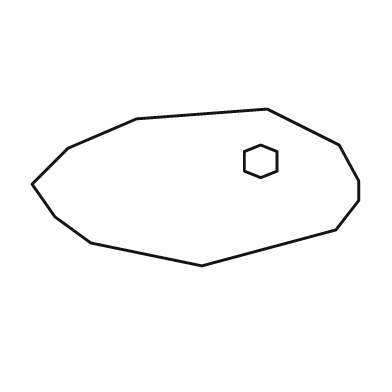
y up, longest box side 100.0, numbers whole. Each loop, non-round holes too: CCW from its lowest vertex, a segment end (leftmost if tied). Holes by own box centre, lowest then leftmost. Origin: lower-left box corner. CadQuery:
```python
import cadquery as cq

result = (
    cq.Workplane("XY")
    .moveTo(52.0, 0.0)
    .lineTo(93.0, 11.0)
    .lineTo(100.0, 20.0)
    .lineTo(100.0, 26.0)
    .lineTo(94.0, 37.0)
    .lineTo(72.0, 48.0)
    .lineTo(32.0, 45.0)
    .lineTo(11.0, 36.0)
    .lineTo(0.0, 25.0)
    .lineTo(7.0, 15.0)
    .lineTo(18.0, 7.0)
    .close()
    .moveTo(70.0, 27.0)
    .lineTo(75.0, 29.0)
    .lineTo(75.0, 35.0)
    .lineTo(70.0, 37.0)
    .lineTo(65.0, 35.0)
    .lineTo(65.0, 29.0)
    .close()
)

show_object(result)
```